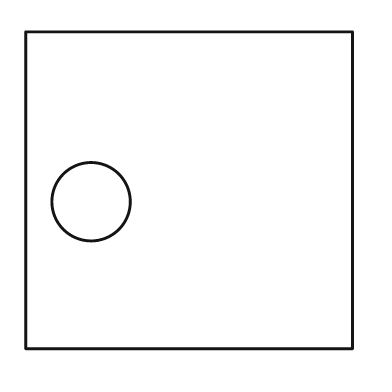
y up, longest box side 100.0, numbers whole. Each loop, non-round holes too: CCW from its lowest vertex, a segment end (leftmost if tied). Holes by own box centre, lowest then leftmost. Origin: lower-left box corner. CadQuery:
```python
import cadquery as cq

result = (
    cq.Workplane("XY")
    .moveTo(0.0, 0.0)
    .lineTo(100.0, 0.0)
    .lineTo(100.0, 97.0)
    .lineTo(0.0, 97.0)
    .close()
    .moveTo(20.0, 45.0)
    .circle(12.0)
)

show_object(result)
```